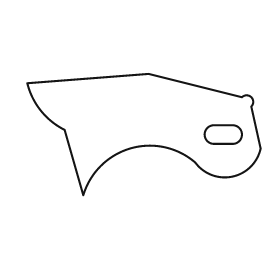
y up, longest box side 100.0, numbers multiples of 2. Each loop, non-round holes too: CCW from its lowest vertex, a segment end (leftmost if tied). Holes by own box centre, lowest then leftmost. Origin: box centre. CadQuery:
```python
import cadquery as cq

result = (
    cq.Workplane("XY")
    .moveTo(-26.0, -26.0)
    .threePointArc((-6.0, -6.0), (22.0, -12.0))
    .threePointArc((38.0, -18.0), (50.0, -6.0))
    .lineTo(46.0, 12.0)
    .threePointArc((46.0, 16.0), (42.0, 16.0))
    .lineTo(2.0, 26.0)
    .lineTo(-50.0, 22.0)
    .threePointArc((-44.0, 10.0), (-34.0, 2.0))
    .close()
    .moveTo(30.0, -4.0)
    .lineTo(38.0, -4.0)
    .threePointArc((42.0, 0.0), (38.0, 4.0))
    .lineTo(30.0, 4.0)
    .threePointArc((26.0, 0.0), (30.0, -4.0))
    .close()
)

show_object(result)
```